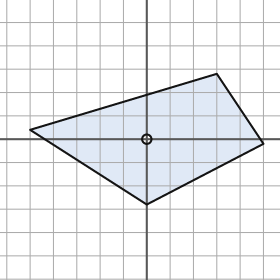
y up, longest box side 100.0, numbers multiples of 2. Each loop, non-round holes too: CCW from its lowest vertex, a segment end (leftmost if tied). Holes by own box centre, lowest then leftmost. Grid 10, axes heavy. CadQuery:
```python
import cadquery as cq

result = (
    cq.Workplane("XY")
    .moveTo(0.0, -28.0)
    .lineTo(50.0, -2.0)
    .lineTo(30.0, 28.0)
    .lineTo(-50.0, 4.0)
    .close()
    .moveTo(0.0, 0.0)
    .circle(2.0)
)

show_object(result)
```